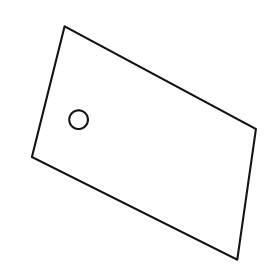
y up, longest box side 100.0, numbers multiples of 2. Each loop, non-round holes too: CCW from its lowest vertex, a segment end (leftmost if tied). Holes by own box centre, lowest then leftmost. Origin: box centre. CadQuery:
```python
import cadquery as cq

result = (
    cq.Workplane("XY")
    .moveTo(40.0, -50.0)
    .lineTo(48.0, 6.0)
    .lineTo(-34.0, 50.0)
    .lineTo(-48.0, -6.0)
    .close()
    .moveTo(-28.0, 10.0)
    .circle(4.0)
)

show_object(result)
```